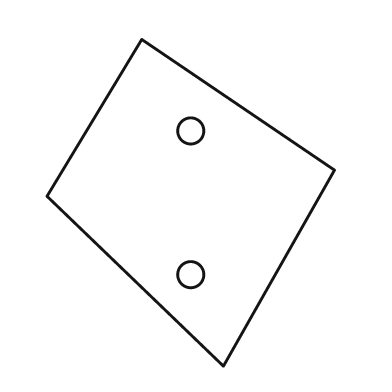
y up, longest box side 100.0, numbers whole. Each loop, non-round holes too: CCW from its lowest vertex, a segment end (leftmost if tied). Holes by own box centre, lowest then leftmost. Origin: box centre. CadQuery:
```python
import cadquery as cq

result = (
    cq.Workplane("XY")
    .moveTo(10.0, -50.0)
    .lineTo(44.0, 10.0)
    .lineTo(-15.0, 50.0)
    .lineTo(-44.0, 2.0)
    .close()
    .moveTo(0.0, -22.0)
    .circle(4.0)
    .moveTo(0.0, 22.0)
    .circle(4.0)
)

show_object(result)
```